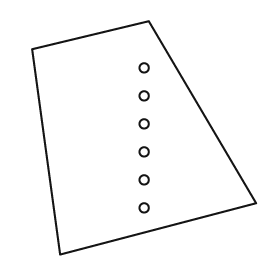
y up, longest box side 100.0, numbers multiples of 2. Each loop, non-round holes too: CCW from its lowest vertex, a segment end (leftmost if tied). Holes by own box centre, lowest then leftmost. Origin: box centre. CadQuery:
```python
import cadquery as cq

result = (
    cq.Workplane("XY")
    .moveTo(-36.0, -50.0)
    .lineTo(48.0, -28.0)
    .lineTo(2.0, 50.0)
    .lineTo(-48.0, 38.0)
    .close()
    .moveTo(0.0, -30.0)
    .circle(2.0)
    .moveTo(0.0, -18.0)
    .circle(2.0)
    .moveTo(0.0, -6.0)
    .circle(2.0)
    .moveTo(0.0, 6.0)
    .circle(2.0)
    .moveTo(0.0, 18.0)
    .circle(2.0)
    .moveTo(0.0, 30.0)
    .circle(2.0)
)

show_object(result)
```